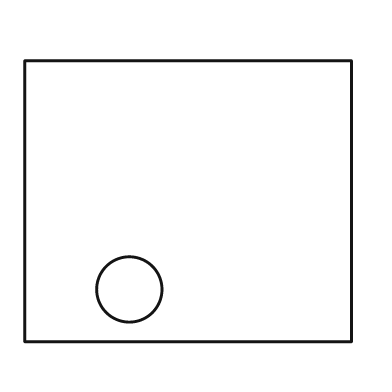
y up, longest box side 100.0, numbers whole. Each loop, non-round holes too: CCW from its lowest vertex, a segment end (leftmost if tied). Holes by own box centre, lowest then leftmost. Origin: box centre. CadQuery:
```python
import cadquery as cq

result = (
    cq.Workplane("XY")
    .moveTo(-50.0, -43.0)
    .lineTo(50.0, -43.0)
    .lineTo(50.0, 43.0)
    .lineTo(-50.0, 43.0)
    .close()
    .moveTo(-18.0, -27.0)
    .circle(10.0)
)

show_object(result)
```